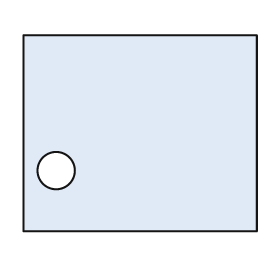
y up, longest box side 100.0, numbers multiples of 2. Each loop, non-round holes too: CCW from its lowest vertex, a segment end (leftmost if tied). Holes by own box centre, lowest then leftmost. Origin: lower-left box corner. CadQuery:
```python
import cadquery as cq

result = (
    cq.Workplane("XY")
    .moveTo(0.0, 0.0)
    .lineTo(100.0, 0.0)
    .lineTo(100.0, 84.0)
    .lineTo(0.0, 84.0)
    .close()
    .moveTo(14.0, 26.0)
    .circle(8.0)
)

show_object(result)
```